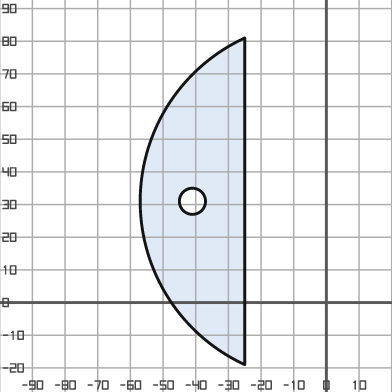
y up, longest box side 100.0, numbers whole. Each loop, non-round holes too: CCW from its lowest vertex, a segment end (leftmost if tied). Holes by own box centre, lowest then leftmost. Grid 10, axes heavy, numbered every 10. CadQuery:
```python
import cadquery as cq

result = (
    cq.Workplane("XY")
    .moveTo(-25.0, -19.0)
    .lineTo(-25.0, 81.0)
    .threePointArc((-57.0, 31.0), (-25.0, -19.0))
    .close()
    .moveTo(-41.0, 31.0)
    .circle(4.0)
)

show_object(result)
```